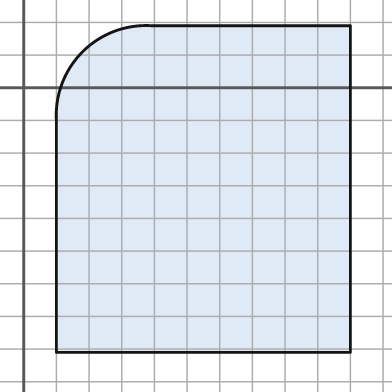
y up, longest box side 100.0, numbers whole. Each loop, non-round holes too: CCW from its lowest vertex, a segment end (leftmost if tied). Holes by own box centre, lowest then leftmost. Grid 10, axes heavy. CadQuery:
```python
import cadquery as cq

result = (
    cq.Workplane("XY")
    .moveTo(10.0, -81.0)
    .lineTo(100.0, -81.0)
    .lineTo(100.0, 19.0)
    .lineTo(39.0, 19.0)
    .threePointArc((18.0, 11.0), (10.0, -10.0))
    .close()
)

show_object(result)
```